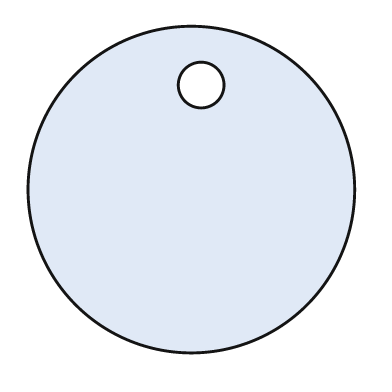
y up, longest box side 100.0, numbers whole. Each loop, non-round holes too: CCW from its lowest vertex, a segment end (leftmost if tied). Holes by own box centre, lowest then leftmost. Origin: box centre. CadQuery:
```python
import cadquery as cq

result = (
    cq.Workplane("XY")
    .moveTo(0.0, 0.0)
    .circle(50.0)
    .moveTo(3.0, 32.0)
    .circle(7.0)
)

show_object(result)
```